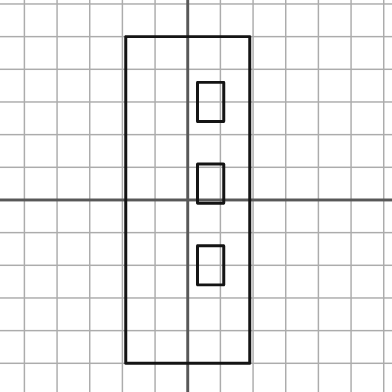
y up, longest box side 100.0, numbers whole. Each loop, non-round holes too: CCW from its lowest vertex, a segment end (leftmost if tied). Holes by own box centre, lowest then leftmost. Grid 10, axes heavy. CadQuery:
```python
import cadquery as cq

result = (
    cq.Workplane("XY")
    .moveTo(-19.0, -50.0)
    .lineTo(19.0, -50.0)
    .lineTo(19.0, 50.0)
    .lineTo(-19.0, 50.0)
    .close()
    .moveTo(3.0, -26.0)
    .lineTo(11.0, -26.0)
    .lineTo(11.0, -14.0)
    .lineTo(3.0, -14.0)
    .close()
    .moveTo(3.0, -1.0)
    .lineTo(11.0, -1.0)
    .lineTo(11.0, 11.0)
    .lineTo(3.0, 11.0)
    .close()
    .moveTo(3.0, 24.0)
    .lineTo(11.0, 24.0)
    .lineTo(11.0, 36.0)
    .lineTo(3.0, 36.0)
    .close()
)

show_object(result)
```